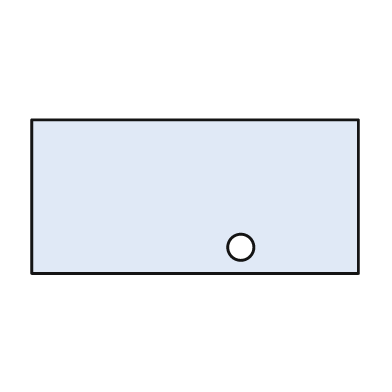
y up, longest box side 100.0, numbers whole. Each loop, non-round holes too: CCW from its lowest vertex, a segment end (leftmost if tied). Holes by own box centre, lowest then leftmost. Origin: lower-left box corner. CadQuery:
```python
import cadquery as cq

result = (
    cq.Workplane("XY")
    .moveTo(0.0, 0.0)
    .lineTo(100.0, 0.0)
    .lineTo(100.0, 47.0)
    .lineTo(0.0, 47.0)
    .close()
    .moveTo(64.0, 8.0)
    .circle(4.0)
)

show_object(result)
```